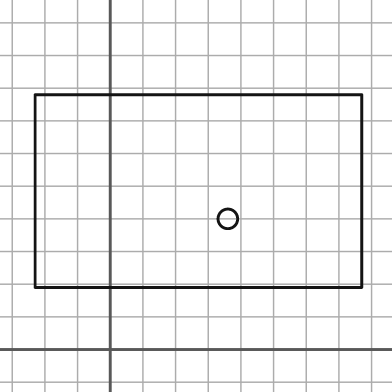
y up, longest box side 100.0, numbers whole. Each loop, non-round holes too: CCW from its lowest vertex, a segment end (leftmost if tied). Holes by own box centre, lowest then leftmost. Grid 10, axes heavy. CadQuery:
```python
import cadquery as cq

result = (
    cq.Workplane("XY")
    .moveTo(-23.0, 19.0)
    .lineTo(77.0, 19.0)
    .lineTo(77.0, 78.0)
    .lineTo(-23.0, 78.0)
    .close()
    .moveTo(36.0, 40.0)
    .circle(3.0)
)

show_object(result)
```